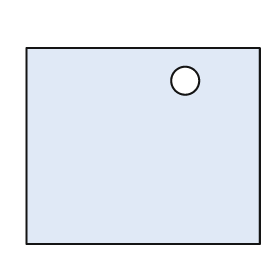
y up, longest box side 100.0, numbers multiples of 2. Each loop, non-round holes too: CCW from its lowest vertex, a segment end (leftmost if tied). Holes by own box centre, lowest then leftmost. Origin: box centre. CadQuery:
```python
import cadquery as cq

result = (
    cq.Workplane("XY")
    .moveTo(-50.0, -42.0)
    .lineTo(50.0, -42.0)
    .lineTo(50.0, 42.0)
    .lineTo(-50.0, 42.0)
    .close()
    .moveTo(18.0, 28.0)
    .circle(6.0)
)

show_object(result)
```